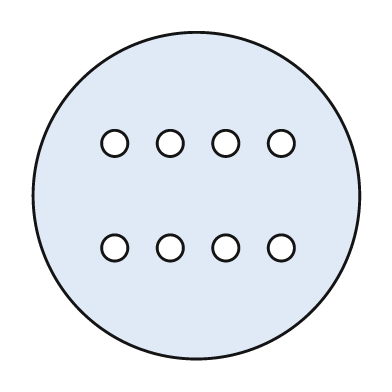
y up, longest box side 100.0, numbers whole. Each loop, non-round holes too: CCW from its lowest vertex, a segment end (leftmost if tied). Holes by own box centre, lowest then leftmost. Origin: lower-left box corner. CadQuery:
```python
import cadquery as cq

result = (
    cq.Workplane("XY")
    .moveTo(50.0, 50.0)
    .circle(50.0)
    .moveTo(25.0, 34.0)
    .circle(4.0)
    .moveTo(42.0, 34.0)
    .circle(4.0)
    .moveTo(59.0, 34.0)
    .circle(4.0)
    .moveTo(76.0, 34.0)
    .circle(4.0)
    .moveTo(25.0, 66.0)
    .circle(4.0)
    .moveTo(42.0, 66.0)
    .circle(4.0)
    .moveTo(59.0, 66.0)
    .circle(4.0)
    .moveTo(76.0, 66.0)
    .circle(4.0)
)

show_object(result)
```